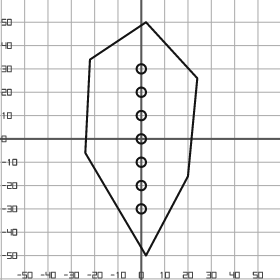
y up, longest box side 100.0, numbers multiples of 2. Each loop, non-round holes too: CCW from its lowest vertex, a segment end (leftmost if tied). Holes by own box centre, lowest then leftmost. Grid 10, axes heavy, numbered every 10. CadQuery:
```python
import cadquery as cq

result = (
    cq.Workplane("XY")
    .moveTo(2.0, -50.0)
    .lineTo(20.0, -16.0)
    .lineTo(24.0, 26.0)
    .lineTo(2.0, 50.0)
    .lineTo(-22.0, 34.0)
    .lineTo(-24.0, -6.0)
    .close()
    .moveTo(0.0, -30.0)
    .circle(2.0)
    .moveTo(0.0, -20.0)
    .circle(2.0)
    .moveTo(0.0, -10.0)
    .circle(2.0)
    .moveTo(0.0, 0.0)
    .circle(2.0)
    .moveTo(0.0, 10.0)
    .circle(2.0)
    .moveTo(0.0, 20.0)
    .circle(2.0)
    .moveTo(0.0, 30.0)
    .circle(2.0)
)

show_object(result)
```